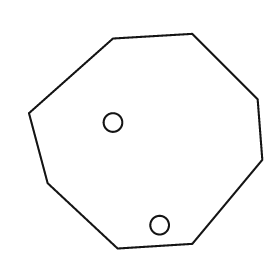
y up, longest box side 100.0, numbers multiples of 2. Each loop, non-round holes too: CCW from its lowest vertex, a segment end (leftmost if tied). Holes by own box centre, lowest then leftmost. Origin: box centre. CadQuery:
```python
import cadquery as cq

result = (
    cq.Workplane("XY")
    .moveTo(-12.0, -46.0)
    .lineTo(20.0, -44.0)
    .lineTo(50.0, -8.0)
    .lineTo(48.0, 18.0)
    .lineTo(20.0, 46.0)
    .lineTo(-14.0, 44.0)
    .lineTo(-50.0, 12.0)
    .lineTo(-42.0, -18.0)
    .close()
    .moveTo(6.0, -36.0)
    .circle(4.0)
    .moveTo(-14.0, 8.0)
    .circle(4.0)
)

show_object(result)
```